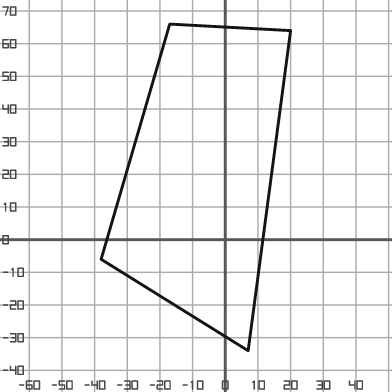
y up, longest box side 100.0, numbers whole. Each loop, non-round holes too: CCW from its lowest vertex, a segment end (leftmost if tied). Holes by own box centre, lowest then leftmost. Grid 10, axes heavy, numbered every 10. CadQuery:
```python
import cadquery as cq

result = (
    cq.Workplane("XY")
    .moveTo(7.0, -34.0)
    .lineTo(20.0, 64.0)
    .lineTo(-17.0, 66.0)
    .lineTo(-38.0, -6.0)
    .close()
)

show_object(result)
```